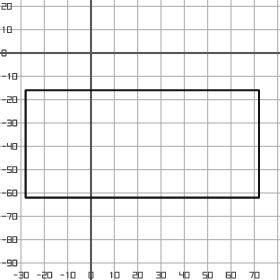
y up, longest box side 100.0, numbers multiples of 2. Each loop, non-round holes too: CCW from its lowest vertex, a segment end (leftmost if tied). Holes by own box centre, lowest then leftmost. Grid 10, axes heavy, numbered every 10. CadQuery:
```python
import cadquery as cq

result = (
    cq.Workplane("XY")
    .moveTo(-28.0, -62.0)
    .lineTo(72.0, -62.0)
    .lineTo(72.0, -16.0)
    .lineTo(-28.0, -16.0)
    .close()
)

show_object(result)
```